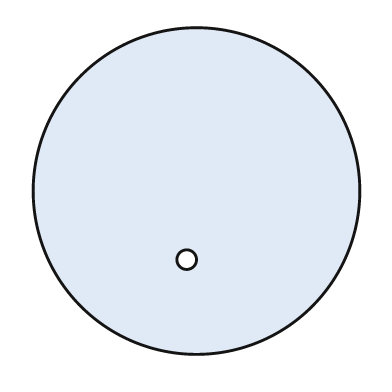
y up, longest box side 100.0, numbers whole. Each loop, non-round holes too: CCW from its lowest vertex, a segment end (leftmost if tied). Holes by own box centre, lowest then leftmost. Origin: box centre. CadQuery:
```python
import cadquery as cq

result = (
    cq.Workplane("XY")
    .moveTo(0.0, 0.0)
    .circle(50.0)
    .moveTo(-3.0, -21.0)
    .circle(3.0)
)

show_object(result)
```